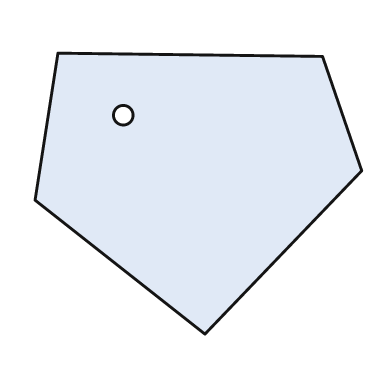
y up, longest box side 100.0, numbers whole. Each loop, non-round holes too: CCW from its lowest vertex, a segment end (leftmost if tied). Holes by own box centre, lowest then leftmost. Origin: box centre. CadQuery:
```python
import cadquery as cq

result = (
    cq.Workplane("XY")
    .moveTo(2.0, -43.0)
    .lineTo(50.0, 7.0)
    .lineTo(38.0, 42.0)
    .lineTo(-43.0, 43.0)
    .lineTo(-50.0, -2.0)
    .close()
    .moveTo(-23.0, 24.0)
    .circle(3.0)
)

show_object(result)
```